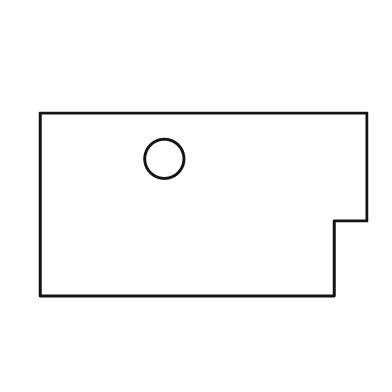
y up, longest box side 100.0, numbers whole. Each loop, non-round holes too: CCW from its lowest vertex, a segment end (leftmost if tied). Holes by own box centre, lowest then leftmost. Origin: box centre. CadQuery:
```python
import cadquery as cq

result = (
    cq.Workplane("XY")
    .moveTo(-50.0, -28.0)
    .lineTo(40.0, -28.0)
    .lineTo(40.0, -5.0)
    .lineTo(50.0, -5.0)
    .lineTo(50.0, 28.0)
    .lineTo(-50.0, 28.0)
    .close()
    .moveTo(-12.0, 14.0)
    .circle(6.0)
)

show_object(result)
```